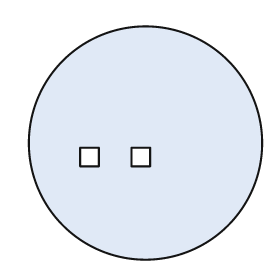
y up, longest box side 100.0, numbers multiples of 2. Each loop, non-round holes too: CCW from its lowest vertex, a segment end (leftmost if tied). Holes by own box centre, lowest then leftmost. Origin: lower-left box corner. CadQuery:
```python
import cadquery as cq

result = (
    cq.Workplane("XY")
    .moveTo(50.0, 50.0)
    .circle(50.0)
    .moveTo(22.0, 40.0)
    .lineTo(30.0, 40.0)
    .lineTo(30.0, 48.0)
    .lineTo(22.0, 48.0)
    .close()
    .moveTo(44.0, 40.0)
    .lineTo(52.0, 40.0)
    .lineTo(52.0, 48.0)
    .lineTo(44.0, 48.0)
    .close()
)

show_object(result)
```